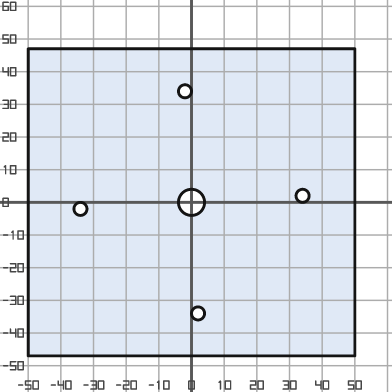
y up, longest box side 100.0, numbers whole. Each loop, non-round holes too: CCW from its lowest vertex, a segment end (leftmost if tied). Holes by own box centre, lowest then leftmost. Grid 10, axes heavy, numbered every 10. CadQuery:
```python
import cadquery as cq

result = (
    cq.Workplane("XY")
    .moveTo(-50.0, -47.0)
    .lineTo(50.0, -47.0)
    .lineTo(50.0, 47.0)
    .lineTo(-50.0, 47.0)
    .close()
    .moveTo(2.0, -34.0)
    .circle(2.0)
    .moveTo(-34.0, -2.0)
    .circle(2.0)
    .moveTo(0.0, 0.0)
    .circle(4.0)
    .moveTo(34.0, 2.0)
    .circle(2.0)
    .moveTo(-2.0, 34.0)
    .circle(2.0)
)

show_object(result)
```